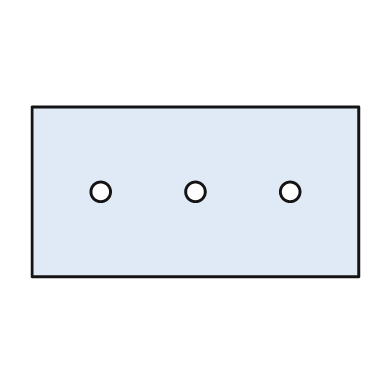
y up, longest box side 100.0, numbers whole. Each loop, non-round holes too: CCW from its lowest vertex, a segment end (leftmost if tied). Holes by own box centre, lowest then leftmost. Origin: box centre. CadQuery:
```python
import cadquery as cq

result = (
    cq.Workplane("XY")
    .moveTo(-50.0, -26.0)
    .lineTo(50.0, -26.0)
    .lineTo(50.0, 26.0)
    .lineTo(-50.0, 26.0)
    .close()
    .moveTo(-29.0, 0.0)
    .circle(3.0)
    .moveTo(0.0, 0.0)
    .circle(3.0)
    .moveTo(29.0, 0.0)
    .circle(3.0)
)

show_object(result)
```